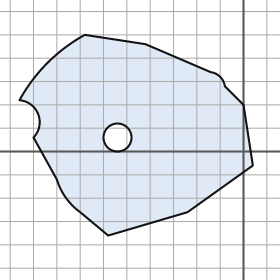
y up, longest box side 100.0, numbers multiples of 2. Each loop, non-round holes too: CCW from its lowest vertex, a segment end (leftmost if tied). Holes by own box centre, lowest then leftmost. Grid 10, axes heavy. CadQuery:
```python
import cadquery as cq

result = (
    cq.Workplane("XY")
    .moveTo(-58.0, -36.0)
    .lineTo(-24.0, -26.0)
    .lineTo(4.0, -6.0)
    .lineTo(0.0, 20.0)
    .lineTo(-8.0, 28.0)
    .threePointArc((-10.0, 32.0), (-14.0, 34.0))
    .lineTo(-42.0, 46.0)
    .lineTo(-68.0, 50.0)
    .threePointArc((-84.0, 38.0), (-96.0, 22.0))
    .threePointArc((-88.0, 16.0), (-90.0, 6.0))
    .lineTo(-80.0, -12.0)
    .threePointArc((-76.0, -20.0), (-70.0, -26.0))
    .close()
    .moveTo(-54.0, 6.0)
    .circle(6.0)
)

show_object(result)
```